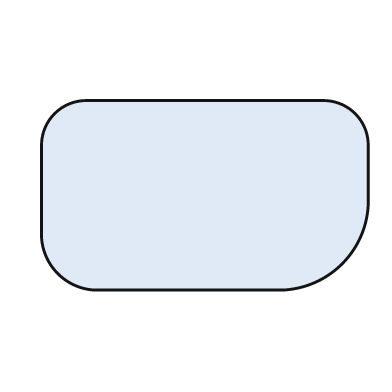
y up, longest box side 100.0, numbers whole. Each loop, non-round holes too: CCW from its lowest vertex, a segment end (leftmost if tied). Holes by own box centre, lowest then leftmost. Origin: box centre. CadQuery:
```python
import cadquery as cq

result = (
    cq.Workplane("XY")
    .moveTo(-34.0, -29.0)
    .lineTo(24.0, -29.0)
    .threePointArc((42.0, -21.0), (50.0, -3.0))
    .lineTo(50.0, 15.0)
    .threePointArc((46.0, 25.0), (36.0, 29.0))
    .lineTo(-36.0, 29.0)
    .threePointArc((-46.0, 25.0), (-50.0, 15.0))
    .lineTo(-50.0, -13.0)
    .threePointArc((-45.0, -24.0), (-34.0, -29.0))
    .close()
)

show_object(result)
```